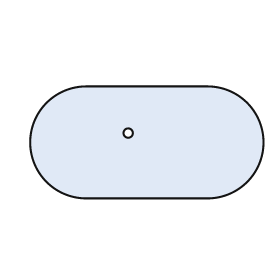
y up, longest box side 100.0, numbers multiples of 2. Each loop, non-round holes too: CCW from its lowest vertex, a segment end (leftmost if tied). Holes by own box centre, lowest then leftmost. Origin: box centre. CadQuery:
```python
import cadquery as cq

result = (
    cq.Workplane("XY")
    .moveTo(-26.0, -24.0)
    .lineTo(26.0, -24.0)
    .threePointArc((50.0, 0.0), (26.0, 24.0))
    .lineTo(-26.0, 24.0)
    .threePointArc((-50.0, 0.0), (-26.0, -24.0))
    .close()
    .moveTo(-8.0, 4.0)
    .circle(2.0)
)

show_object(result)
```